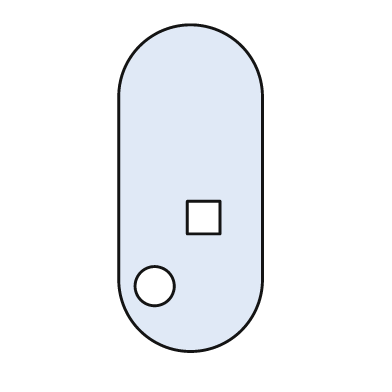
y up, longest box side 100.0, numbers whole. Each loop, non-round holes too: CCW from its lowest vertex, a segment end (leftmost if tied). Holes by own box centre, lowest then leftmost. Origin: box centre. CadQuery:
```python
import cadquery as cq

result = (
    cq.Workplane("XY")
    .moveTo(-22.0, -28.0)
    .threePointArc((0.0, -50.0), (22.0, -28.0))
    .lineTo(22.0, 28.0)
    .threePointArc((0.0, 50.0), (-22.0, 28.0))
    .close()
    .moveTo(-11.0, -30.0)
    .circle(6.0)
    .moveTo(-1.0, -14.0)
    .lineTo(9.0, -14.0)
    .lineTo(9.0, -4.0)
    .lineTo(-1.0, -4.0)
    .close()
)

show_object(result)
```